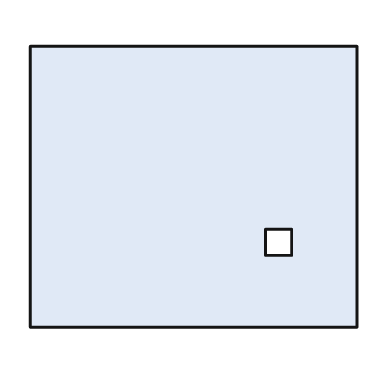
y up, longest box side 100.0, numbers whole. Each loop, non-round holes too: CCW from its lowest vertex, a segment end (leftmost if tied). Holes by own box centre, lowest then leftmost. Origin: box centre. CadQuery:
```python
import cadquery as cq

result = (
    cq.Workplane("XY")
    .moveTo(-50.0, -43.0)
    .lineTo(50.0, -43.0)
    .lineTo(50.0, 43.0)
    .lineTo(-50.0, 43.0)
    .close()
    .moveTo(22.0, -21.0)
    .lineTo(30.0, -21.0)
    .lineTo(30.0, -13.0)
    .lineTo(22.0, -13.0)
    .close()
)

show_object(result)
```